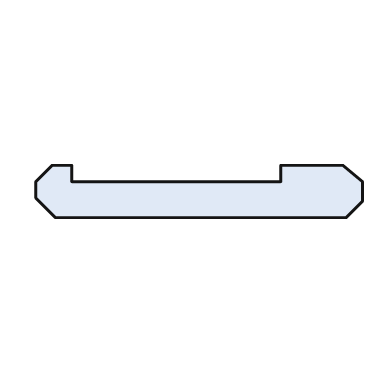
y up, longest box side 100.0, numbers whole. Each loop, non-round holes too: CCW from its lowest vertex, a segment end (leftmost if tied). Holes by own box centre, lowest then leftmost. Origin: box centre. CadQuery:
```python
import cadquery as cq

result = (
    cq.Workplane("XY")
    .moveTo(-44.0, -8.0)
    .lineTo(45.0, -8.0)
    .lineTo(50.0, -3.0)
    .lineTo(50.0, 3.0)
    .lineTo(44.0, 8.0)
    .lineTo(25.0, 8.0)
    .lineTo(25.0, 3.0)
    .lineTo(-39.0, 3.0)
    .lineTo(-39.0, 8.0)
    .lineTo(-45.0, 8.0)
    .lineTo(-50.0, 3.0)
    .lineTo(-50.0, -2.0)
    .close()
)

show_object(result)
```